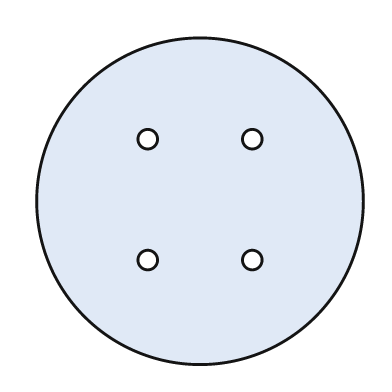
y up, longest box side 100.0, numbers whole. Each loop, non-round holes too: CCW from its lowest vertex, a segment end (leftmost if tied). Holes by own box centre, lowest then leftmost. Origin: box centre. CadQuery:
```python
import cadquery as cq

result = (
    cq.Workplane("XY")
    .moveTo(0.0, 0.0)
    .circle(50.0)
    .moveTo(-16.0, -18.0)
    .circle(3.0)
    .moveTo(16.0, -18.0)
    .circle(3.0)
    .moveTo(-16.0, 19.0)
    .circle(3.0)
    .moveTo(16.0, 19.0)
    .circle(3.0)
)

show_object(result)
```